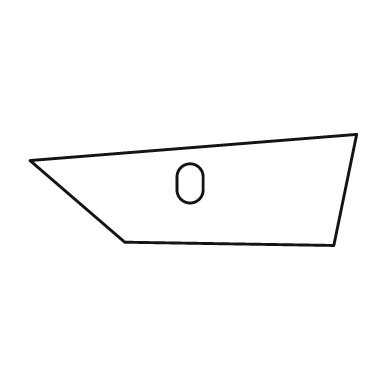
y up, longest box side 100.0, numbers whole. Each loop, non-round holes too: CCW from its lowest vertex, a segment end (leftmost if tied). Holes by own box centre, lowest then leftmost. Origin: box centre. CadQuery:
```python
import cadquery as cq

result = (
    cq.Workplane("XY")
    .moveTo(43.0, -17.0)
    .lineTo(50.0, 17.0)
    .lineTo(-50.0, 9.0)
    .lineTo(-21.0, -16.0)
    .close()
    .moveTo(-5.0, 0.0)
    .threePointArc((-1.0, -4.0), (3.0, 0.0))
    .lineTo(3.0, 4.0)
    .threePointArc((-1.0, 8.0), (-5.0, 4.0))
    .close()
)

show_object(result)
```